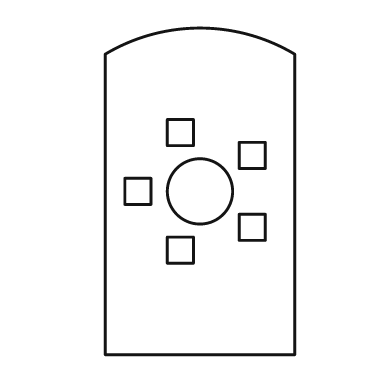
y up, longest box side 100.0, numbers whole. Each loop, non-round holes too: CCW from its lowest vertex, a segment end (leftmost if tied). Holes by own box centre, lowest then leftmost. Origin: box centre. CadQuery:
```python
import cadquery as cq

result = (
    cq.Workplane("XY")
    .moveTo(-29.0, -50.0)
    .lineTo(29.0, -50.0)
    .lineTo(29.0, 42.0)
    .threePointArc((0.0, 50.0), (-29.0, 42.0))
    .close()
    .moveTo(-10.0, -22.0)
    .lineTo(-2.0, -22.0)
    .lineTo(-2.0, -14.0)
    .lineTo(-10.0, -14.0)
    .close()
    .moveTo(12.0, -15.0)
    .lineTo(20.0, -15.0)
    .lineTo(20.0, -7.0)
    .lineTo(12.0, -7.0)
    .close()
    .moveTo(-23.0, -4.0)
    .lineTo(-15.0, -4.0)
    .lineTo(-15.0, 4.0)
    .lineTo(-23.0, 4.0)
    .close()
    .moveTo(0.0, 0.0)
    .circle(10.0)
    .moveTo(12.0, 7.0)
    .lineTo(20.0, 7.0)
    .lineTo(20.0, 15.0)
    .lineTo(12.0, 15.0)
    .close()
    .moveTo(-10.0, 14.0)
    .lineTo(-2.0, 14.0)
    .lineTo(-2.0, 22.0)
    .lineTo(-10.0, 22.0)
    .close()
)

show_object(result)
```